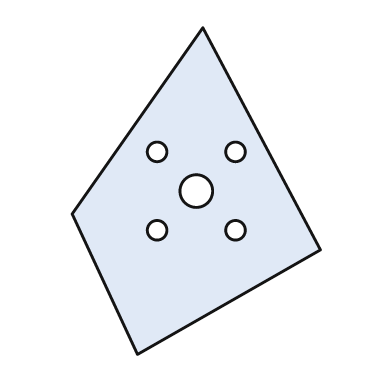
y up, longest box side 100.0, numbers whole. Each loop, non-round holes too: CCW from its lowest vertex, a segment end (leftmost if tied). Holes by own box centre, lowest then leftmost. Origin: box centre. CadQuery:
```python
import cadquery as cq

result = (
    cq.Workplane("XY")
    .moveTo(-18.0, -50.0)
    .lineTo(38.0, -18.0)
    .lineTo(2.0, 50.0)
    .lineTo(-38.0, -7.0)
    .close()
    .moveTo(-12.0, -12.0)
    .circle(3.0)
    .moveTo(12.0, -12.0)
    .circle(3.0)
    .moveTo(0.0, 0.0)
    .circle(5.0)
    .moveTo(-12.0, 12.0)
    .circle(3.0)
    .moveTo(12.0, 12.0)
    .circle(3.0)
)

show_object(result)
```